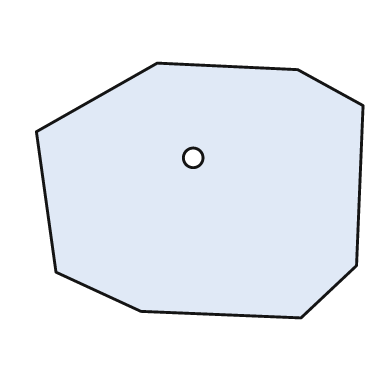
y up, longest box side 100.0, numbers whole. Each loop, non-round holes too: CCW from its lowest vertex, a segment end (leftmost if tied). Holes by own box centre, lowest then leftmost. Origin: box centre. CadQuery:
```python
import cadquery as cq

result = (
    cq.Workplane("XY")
    .moveTo(31.0, -39.0)
    .lineTo(48.0, -23.0)
    .lineTo(50.0, 26.0)
    .lineTo(30.0, 37.0)
    .lineTo(-13.0, 39.0)
    .lineTo(-50.0, 18.0)
    .lineTo(-44.0, -25.0)
    .lineTo(-18.0, -37.0)
    .close()
    .moveTo(-2.0, 10.0)
    .circle(3.0)
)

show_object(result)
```